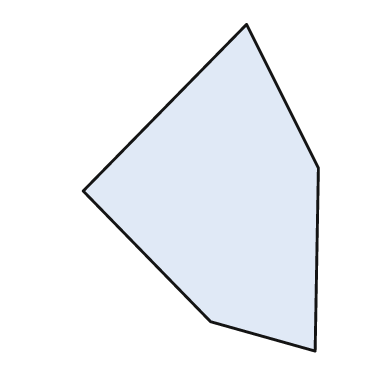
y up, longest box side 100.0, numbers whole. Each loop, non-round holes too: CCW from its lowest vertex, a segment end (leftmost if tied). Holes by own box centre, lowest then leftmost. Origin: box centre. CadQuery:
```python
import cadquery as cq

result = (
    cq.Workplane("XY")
    .moveTo(35.0, -50.0)
    .lineTo(36.0, 6.0)
    .lineTo(14.0, 50.0)
    .lineTo(-36.0, -1.0)
    .lineTo(3.0, -41.0)
    .close()
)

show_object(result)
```